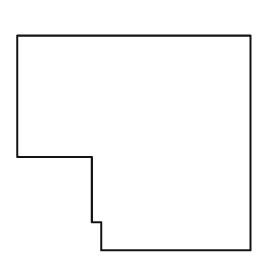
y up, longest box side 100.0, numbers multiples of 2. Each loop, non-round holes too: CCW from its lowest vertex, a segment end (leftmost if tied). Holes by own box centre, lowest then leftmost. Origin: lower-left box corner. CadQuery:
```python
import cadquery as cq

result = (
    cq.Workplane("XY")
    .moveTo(36.0, 0.0)
    .lineTo(100.0, 0.0)
    .lineTo(100.0, 92.0)
    .lineTo(0.0, 92.0)
    .lineTo(0.0, 40.0)
    .lineTo(32.0, 40.0)
    .lineTo(32.0, 12.0)
    .lineTo(36.0, 12.0)
    .close()
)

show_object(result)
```